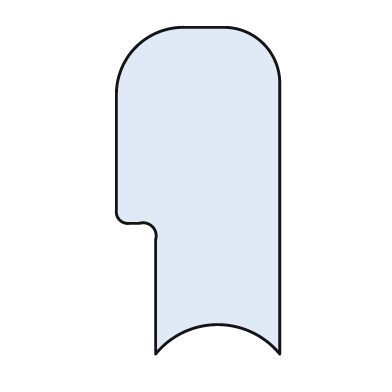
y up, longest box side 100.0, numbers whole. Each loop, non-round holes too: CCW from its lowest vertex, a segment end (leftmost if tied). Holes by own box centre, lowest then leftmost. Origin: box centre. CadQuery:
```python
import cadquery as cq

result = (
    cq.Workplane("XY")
    .moveTo(-13.0, -50.0)
    .threePointArc((6.0, -41.0), (25.0, -50.0))
    .lineTo(25.0, 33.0)
    .threePointArc((20.0, 45.0), (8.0, 50.0))
    .lineTo(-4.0, 50.0)
    .threePointArc((-19.0, 44.0), (-25.0, 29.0))
    .lineTo(-25.0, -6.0)
    .threePointArc((-24.0, -9.0), (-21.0, -10.0))
    .lineTo(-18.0, -10.0)
    .threePointArc((-14.0, -11.0), (-13.0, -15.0))
    .close()
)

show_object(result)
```